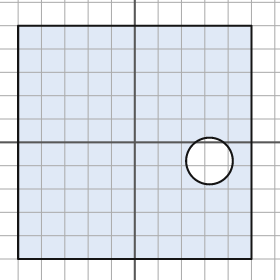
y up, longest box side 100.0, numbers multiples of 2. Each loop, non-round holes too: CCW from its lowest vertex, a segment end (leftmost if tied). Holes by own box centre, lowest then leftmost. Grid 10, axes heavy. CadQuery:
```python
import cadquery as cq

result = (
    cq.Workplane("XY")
    .moveTo(-50.0, -50.0)
    .lineTo(50.0, -50.0)
    .lineTo(50.0, 50.0)
    .lineTo(-50.0, 50.0)
    .close()
    .moveTo(32.0, -8.0)
    .circle(10.0)
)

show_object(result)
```